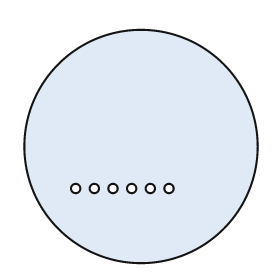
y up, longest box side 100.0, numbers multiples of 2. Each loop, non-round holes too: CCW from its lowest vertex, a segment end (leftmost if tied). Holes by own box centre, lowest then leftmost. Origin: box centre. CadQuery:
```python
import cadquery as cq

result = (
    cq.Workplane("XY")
    .moveTo(0.0, 0.0)
    .circle(50.0)
    .moveTo(-28.0, -18.0)
    .circle(2.0)
    .moveTo(-20.0, -18.0)
    .circle(2.0)
    .moveTo(-12.0, -18.0)
    .circle(2.0)
    .moveTo(-4.0, -18.0)
    .circle(2.0)
    .moveTo(4.0, -18.0)
    .circle(2.0)
    .moveTo(12.0, -18.0)
    .circle(2.0)
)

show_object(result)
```